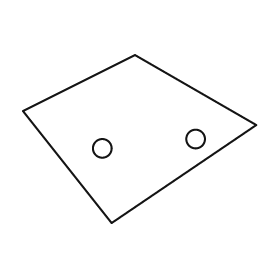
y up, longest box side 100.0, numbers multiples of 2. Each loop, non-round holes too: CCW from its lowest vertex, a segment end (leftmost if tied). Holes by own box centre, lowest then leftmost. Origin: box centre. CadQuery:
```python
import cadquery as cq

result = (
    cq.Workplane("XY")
    .moveTo(-12.0, -36.0)
    .lineTo(50.0, 6.0)
    .lineTo(-2.0, 36.0)
    .lineTo(-50.0, 12.0)
    .close()
    .moveTo(-16.0, -4.0)
    .circle(4.0)
    .moveTo(24.0, 0.0)
    .circle(4.0)
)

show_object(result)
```